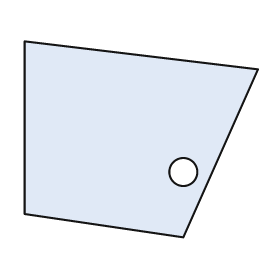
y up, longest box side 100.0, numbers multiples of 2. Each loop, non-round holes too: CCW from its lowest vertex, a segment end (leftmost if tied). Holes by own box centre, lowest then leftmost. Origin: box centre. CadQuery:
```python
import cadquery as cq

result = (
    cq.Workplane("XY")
    .moveTo(18.0, -42.0)
    .lineTo(50.0, 30.0)
    .lineTo(-50.0, 42.0)
    .lineTo(-50.0, -32.0)
    .close()
    .moveTo(18.0, -14.0)
    .circle(6.0)
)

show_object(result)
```